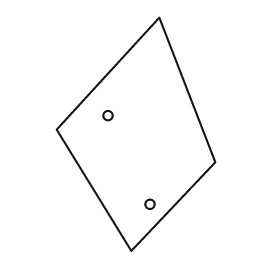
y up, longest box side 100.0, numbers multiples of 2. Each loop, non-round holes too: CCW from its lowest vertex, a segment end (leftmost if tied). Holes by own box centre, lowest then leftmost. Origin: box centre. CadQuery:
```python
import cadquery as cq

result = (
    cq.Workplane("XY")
    .moveTo(-2.0, -50.0)
    .lineTo(34.0, -12.0)
    .lineTo(10.0, 50.0)
    .lineTo(-34.0, 2.0)
    .close()
    .moveTo(6.0, -30.0)
    .circle(2.0)
    .moveTo(-12.0, 8.0)
    .circle(2.0)
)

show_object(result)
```